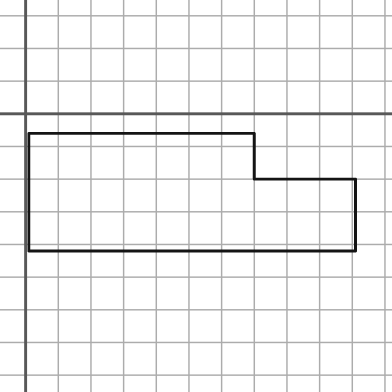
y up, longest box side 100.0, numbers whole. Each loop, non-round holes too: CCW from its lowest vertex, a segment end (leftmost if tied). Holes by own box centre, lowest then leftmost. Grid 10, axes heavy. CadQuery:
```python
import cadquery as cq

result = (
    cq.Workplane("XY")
    .moveTo(1.0, -42.0)
    .lineTo(101.0, -42.0)
    .lineTo(101.0, -20.0)
    .lineTo(70.0, -20.0)
    .lineTo(70.0, -6.0)
    .lineTo(1.0, -6.0)
    .close()
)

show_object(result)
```